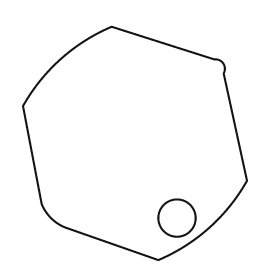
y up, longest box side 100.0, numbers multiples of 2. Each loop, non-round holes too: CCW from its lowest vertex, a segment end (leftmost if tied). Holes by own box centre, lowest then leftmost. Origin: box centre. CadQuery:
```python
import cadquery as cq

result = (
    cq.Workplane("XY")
    .moveTo(10.0, -50.0)
    .threePointArc((32.0, -36.0), (48.0, -16.0))
    .lineTo(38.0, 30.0)
    .threePointArc((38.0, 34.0), (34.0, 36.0))
    .lineTo(-10.0, 50.0)
    .threePointArc((-32.0, 36.0), (-48.0, 16.0))
    .lineTo(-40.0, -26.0)
    .threePointArc((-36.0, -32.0), (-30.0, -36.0))
    .close()
    .moveTo(18.0, -32.0)
    .circle(8.0)
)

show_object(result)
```